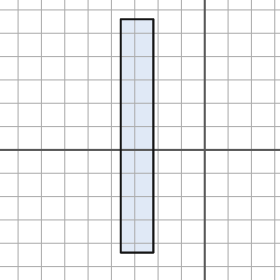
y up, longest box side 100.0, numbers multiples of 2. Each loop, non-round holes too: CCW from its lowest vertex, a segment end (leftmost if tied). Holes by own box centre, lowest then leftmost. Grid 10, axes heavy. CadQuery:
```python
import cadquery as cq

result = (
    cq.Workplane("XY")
    .moveTo(-36.0, -44.0)
    .lineTo(-22.0, -44.0)
    .lineTo(-22.0, 56.0)
    .lineTo(-36.0, 56.0)
    .close()
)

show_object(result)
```